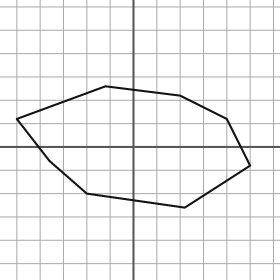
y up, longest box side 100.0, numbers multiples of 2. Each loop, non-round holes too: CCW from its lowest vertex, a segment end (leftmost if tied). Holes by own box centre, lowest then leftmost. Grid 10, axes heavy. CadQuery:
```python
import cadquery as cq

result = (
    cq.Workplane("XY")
    .moveTo(22.0, -26.0)
    .lineTo(50.0, -8.0)
    .lineTo(40.0, 12.0)
    .lineTo(20.0, 22.0)
    .lineTo(-12.0, 26.0)
    .lineTo(-50.0, 12.0)
    .lineTo(-36.0, -6.0)
    .lineTo(-20.0, -20.0)
    .close()
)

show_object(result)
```